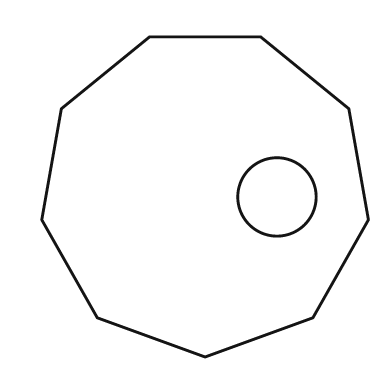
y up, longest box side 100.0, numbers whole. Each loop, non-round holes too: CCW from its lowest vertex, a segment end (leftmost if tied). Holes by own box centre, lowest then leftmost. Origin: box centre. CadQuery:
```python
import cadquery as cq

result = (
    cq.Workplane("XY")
    .moveTo(0.0, -49.0)
    .lineTo(33.0, -37.0)
    .lineTo(50.0, -7.0)
    .lineTo(44.0, 27.0)
    .lineTo(17.0, 49.0)
    .lineTo(-17.0, 49.0)
    .lineTo(-44.0, 27.0)
    .lineTo(-50.0, -7.0)
    .lineTo(-33.0, -37.0)
    .close()
    .moveTo(22.0, 0.0)
    .circle(12.0)
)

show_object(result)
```